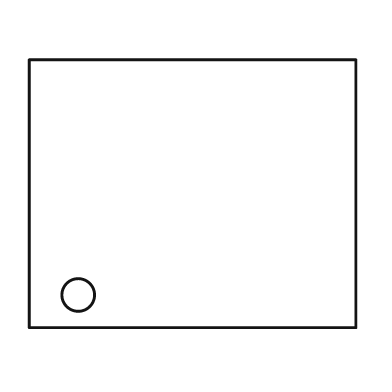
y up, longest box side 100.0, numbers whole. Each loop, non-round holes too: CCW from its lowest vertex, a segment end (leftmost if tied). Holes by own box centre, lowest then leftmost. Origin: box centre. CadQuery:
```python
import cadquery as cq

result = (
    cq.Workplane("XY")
    .moveTo(-50.0, -41.0)
    .lineTo(50.0, -41.0)
    .lineTo(50.0, 41.0)
    .lineTo(-50.0, 41.0)
    .close()
    .moveTo(-35.0, -31.0)
    .circle(5.0)
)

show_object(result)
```